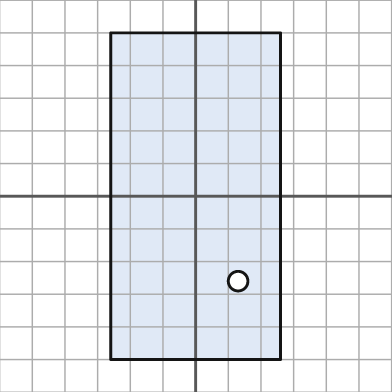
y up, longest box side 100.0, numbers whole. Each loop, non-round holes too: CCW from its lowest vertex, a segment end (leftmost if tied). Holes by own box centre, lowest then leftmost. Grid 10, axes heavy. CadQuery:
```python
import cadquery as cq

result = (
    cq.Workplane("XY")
    .moveTo(-26.0, -50.0)
    .lineTo(26.0, -50.0)
    .lineTo(26.0, 50.0)
    .lineTo(-26.0, 50.0)
    .close()
    .moveTo(13.0, -26.0)
    .circle(3.0)
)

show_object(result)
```